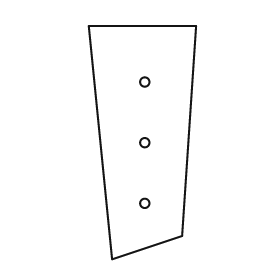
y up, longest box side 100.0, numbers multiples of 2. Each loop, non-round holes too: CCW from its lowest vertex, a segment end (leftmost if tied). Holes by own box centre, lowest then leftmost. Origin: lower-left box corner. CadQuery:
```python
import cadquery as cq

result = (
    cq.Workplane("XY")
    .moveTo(10.0, 0.0)
    .lineTo(40.0, 10.0)
    .lineTo(46.0, 100.0)
    .lineTo(0.0, 100.0)
    .close()
    .moveTo(24.0, 24.0)
    .circle(2.0)
    .moveTo(24.0, 50.0)
    .circle(2.0)
    .moveTo(24.0, 76.0)
    .circle(2.0)
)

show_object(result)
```